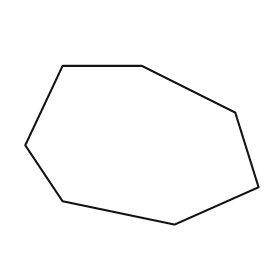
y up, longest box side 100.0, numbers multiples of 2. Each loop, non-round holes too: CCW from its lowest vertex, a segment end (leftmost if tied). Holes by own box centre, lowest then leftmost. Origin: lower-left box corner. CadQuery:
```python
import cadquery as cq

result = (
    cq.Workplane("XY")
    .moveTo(64.0, 0.0)
    .lineTo(100.0, 16.0)
    .lineTo(90.0, 48.0)
    .lineTo(50.0, 68.0)
    .lineTo(16.0, 68.0)
    .lineTo(0.0, 34.0)
    .lineTo(16.0, 10.0)
    .close()
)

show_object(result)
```